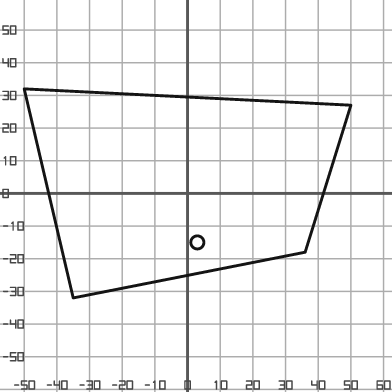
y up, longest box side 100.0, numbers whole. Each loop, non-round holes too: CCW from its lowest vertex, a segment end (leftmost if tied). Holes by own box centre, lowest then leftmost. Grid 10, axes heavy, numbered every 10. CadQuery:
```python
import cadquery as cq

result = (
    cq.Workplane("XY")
    .moveTo(-35.0, -32.0)
    .lineTo(36.0, -18.0)
    .lineTo(50.0, 27.0)
    .lineTo(-50.0, 32.0)
    .close()
    .moveTo(3.0, -15.0)
    .circle(2.0)
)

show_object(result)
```